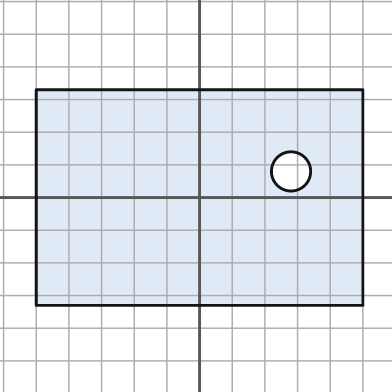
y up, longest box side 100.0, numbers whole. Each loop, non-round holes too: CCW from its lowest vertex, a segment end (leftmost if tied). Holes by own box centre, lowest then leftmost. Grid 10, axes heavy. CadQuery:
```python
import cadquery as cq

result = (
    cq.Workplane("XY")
    .moveTo(-50.0, -33.0)
    .lineTo(50.0, -33.0)
    .lineTo(50.0, 33.0)
    .lineTo(-50.0, 33.0)
    .close()
    .moveTo(28.0, 8.0)
    .circle(6.0)
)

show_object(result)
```